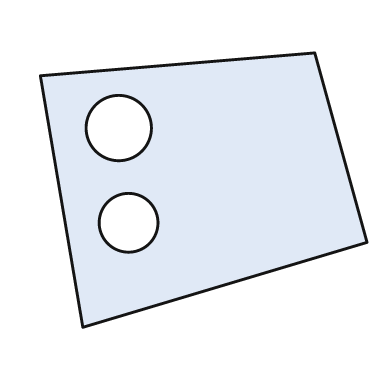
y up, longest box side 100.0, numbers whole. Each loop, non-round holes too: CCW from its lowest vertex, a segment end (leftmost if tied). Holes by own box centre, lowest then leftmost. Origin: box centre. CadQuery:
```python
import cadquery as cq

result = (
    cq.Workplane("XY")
    .moveTo(-37.0, -42.0)
    .lineTo(50.0, -16.0)
    .lineTo(34.0, 42.0)
    .lineTo(-50.0, 35.0)
    .close()
    .moveTo(-23.0, -10.0)
    .circle(9.0)
    .moveTo(-26.0, 19.0)
    .circle(10.0)
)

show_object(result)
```